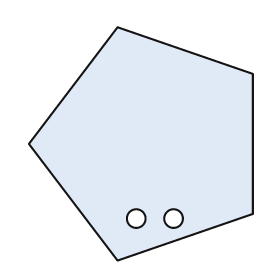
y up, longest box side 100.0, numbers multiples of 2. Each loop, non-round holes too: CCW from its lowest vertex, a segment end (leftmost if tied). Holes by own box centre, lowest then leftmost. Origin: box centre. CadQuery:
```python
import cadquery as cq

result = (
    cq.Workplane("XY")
    .moveTo(-10.0, -50.0)
    .lineTo(48.0, -30.0)
    .lineTo(48.0, 30.0)
    .lineTo(-10.0, 50.0)
    .lineTo(-48.0, 0.0)
    .close()
    .moveTo(-2.0, -32.0)
    .circle(4.0)
    .moveTo(14.0, -32.0)
    .circle(4.0)
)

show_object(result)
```